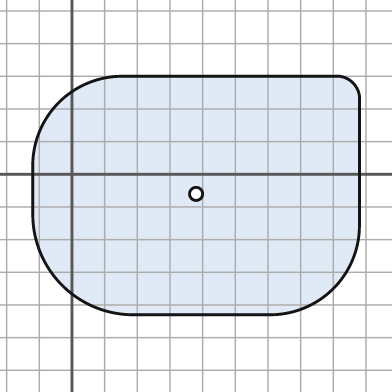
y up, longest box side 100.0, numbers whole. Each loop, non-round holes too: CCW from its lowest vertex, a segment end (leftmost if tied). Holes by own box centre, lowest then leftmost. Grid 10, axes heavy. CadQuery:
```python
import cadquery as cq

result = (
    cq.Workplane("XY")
    .moveTo(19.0, -43.0)
    .lineTo(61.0, -43.0)
    .threePointArc((80.0, -35.0), (88.0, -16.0))
    .lineTo(88.0, 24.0)
    .threePointArc((86.0, 28.0), (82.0, 30.0))
    .lineTo(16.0, 30.0)
    .threePointArc((-4.0, 22.0), (-12.0, 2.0))
    .lineTo(-12.0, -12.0)
    .threePointArc((-3.0, -34.0), (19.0, -43.0))
    .close()
    .moveTo(38.0, -6.0)
    .circle(2.0)
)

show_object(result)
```